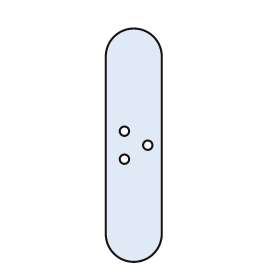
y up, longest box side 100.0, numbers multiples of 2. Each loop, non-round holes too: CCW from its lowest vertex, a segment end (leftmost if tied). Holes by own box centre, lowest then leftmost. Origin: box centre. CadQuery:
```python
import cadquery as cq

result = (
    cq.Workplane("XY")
    .moveTo(-12.0, -38.0)
    .threePointArc((0.0, -50.0), (12.0, -38.0))
    .lineTo(12.0, 38.0)
    .threePointArc((0.0, 50.0), (-12.0, 38.0))
    .close()
    .moveTo(-4.0, -6.0)
    .circle(2.0)
    .moveTo(6.0, 0.0)
    .circle(2.0)
    .moveTo(-4.0, 6.0)
    .circle(2.0)
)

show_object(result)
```